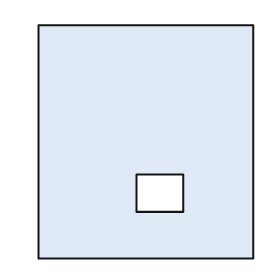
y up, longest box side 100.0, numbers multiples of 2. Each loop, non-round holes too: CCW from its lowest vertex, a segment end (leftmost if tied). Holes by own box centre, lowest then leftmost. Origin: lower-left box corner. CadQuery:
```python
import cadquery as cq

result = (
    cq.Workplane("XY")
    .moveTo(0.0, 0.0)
    .lineTo(92.0, 0.0)
    .lineTo(92.0, 100.0)
    .lineTo(0.0, 100.0)
    .close()
    .moveTo(42.0, 20.0)
    .lineTo(62.0, 20.0)
    .lineTo(62.0, 36.0)
    .lineTo(42.0, 36.0)
    .close()
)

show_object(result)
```